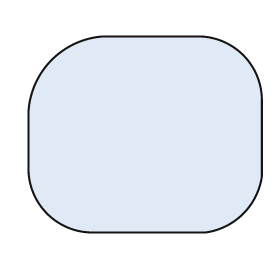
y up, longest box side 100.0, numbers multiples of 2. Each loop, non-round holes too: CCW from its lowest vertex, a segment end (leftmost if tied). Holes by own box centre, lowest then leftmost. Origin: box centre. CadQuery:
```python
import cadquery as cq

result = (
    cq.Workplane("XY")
    .moveTo(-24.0, -42.0)
    .lineTo(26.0, -42.0)
    .threePointArc((42.0, -34.0), (50.0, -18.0))
    .lineTo(50.0, 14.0)
    .threePointArc((42.0, 34.0), (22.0, 42.0))
    .lineTo(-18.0, 42.0)
    .threePointArc((-40.0, 32.0), (-50.0, 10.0))
    .lineTo(-50.0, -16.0)
    .threePointArc((-42.0, -34.0), (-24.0, -42.0))
    .close()
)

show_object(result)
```